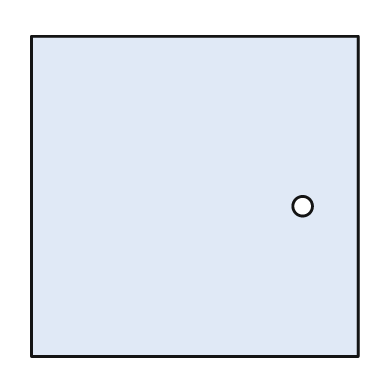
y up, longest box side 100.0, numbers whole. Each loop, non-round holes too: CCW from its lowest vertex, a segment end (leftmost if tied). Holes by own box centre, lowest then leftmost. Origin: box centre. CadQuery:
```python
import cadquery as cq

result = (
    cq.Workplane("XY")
    .moveTo(-50.0, -49.0)
    .lineTo(50.0, -49.0)
    .lineTo(50.0, 49.0)
    .lineTo(-50.0, 49.0)
    .close()
    .moveTo(33.0, -3.0)
    .circle(3.0)
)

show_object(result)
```